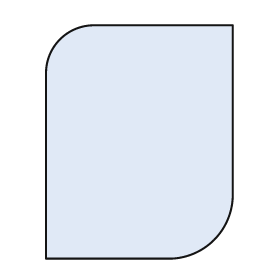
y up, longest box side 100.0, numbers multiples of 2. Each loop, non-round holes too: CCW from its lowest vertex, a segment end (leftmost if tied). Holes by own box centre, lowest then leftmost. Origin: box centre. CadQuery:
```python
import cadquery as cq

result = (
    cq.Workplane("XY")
    .moveTo(-40.0, -50.0)
    .lineTo(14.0, -50.0)
    .threePointArc((32.0, -42.0), (40.0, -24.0))
    .lineTo(40.0, 50.0)
    .lineTo(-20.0, 50.0)
    .threePointArc((-34.0, 44.0), (-40.0, 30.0))
    .close()
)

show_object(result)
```